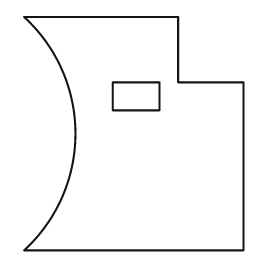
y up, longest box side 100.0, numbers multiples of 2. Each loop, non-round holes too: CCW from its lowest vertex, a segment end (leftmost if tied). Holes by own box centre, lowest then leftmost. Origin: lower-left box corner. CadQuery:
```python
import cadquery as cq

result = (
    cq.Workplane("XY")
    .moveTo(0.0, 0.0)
    .lineTo(94.0, 0.0)
    .lineTo(94.0, 72.0)
    .lineTo(66.0, 72.0)
    .lineTo(66.0, 100.0)
    .lineTo(0.0, 100.0)
    .threePointArc((22.0, 50.0), (0.0, 0.0))
    .close()
    .moveTo(38.0, 60.0)
    .lineTo(58.0, 60.0)
    .lineTo(58.0, 72.0)
    .lineTo(38.0, 72.0)
    .close()
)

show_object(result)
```